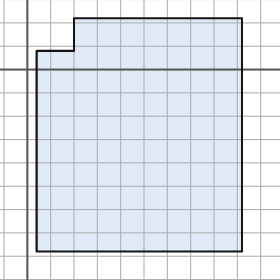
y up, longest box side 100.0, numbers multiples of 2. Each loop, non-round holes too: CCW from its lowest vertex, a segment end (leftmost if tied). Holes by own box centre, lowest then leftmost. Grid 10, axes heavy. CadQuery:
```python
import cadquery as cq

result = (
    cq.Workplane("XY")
    .moveTo(4.0, -78.0)
    .lineTo(92.0, -78.0)
    .lineTo(92.0, 22.0)
    .lineTo(20.0, 22.0)
    .lineTo(20.0, 8.0)
    .lineTo(4.0, 8.0)
    .close()
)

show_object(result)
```